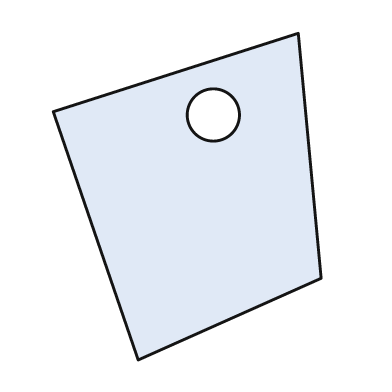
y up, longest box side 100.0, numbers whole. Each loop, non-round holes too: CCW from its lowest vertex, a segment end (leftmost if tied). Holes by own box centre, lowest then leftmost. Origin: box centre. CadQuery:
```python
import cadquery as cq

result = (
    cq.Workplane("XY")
    .moveTo(-15.0, -50.0)
    .lineTo(41.0, -25.0)
    .lineTo(34.0, 50.0)
    .lineTo(-41.0, 26.0)
    .close()
    .moveTo(8.0, 25.0)
    .circle(8.0)
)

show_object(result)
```